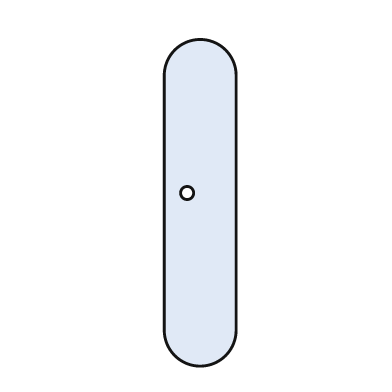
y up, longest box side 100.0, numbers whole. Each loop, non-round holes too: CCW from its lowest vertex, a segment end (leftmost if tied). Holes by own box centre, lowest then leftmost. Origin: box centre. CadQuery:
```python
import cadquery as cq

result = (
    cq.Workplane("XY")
    .moveTo(-11.0, -39.0)
    .threePointArc((0.0, -50.0), (11.0, -39.0))
    .lineTo(11.0, 39.0)
    .threePointArc((0.0, 50.0), (-11.0, 39.0))
    .close()
    .moveTo(-4.0, 3.0)
    .circle(2.0)
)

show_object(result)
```